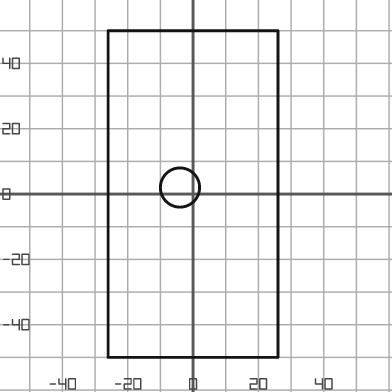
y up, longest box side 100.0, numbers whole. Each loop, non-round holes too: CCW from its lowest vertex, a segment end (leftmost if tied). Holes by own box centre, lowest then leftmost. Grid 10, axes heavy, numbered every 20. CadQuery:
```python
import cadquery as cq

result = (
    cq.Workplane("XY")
    .moveTo(-26.0, -50.0)
    .lineTo(26.0, -50.0)
    .lineTo(26.0, 50.0)
    .lineTo(-26.0, 50.0)
    .close()
    .moveTo(-4.0, 2.0)
    .circle(6.0)
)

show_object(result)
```